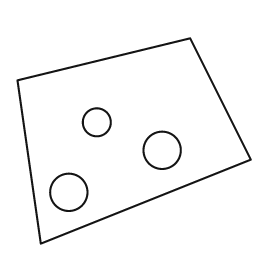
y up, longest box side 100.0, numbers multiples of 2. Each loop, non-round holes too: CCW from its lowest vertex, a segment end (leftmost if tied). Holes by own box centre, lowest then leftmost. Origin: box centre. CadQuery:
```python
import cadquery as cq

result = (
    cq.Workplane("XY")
    .moveTo(-40.0, -44.0)
    .lineTo(50.0, -8.0)
    .lineTo(24.0, 44.0)
    .lineTo(-50.0, 26.0)
    .close()
    .moveTo(-28.0, -22.0)
    .circle(8.0)
    .moveTo(12.0, -4.0)
    .circle(8.0)
    .moveTo(-16.0, 8.0)
    .circle(6.0)
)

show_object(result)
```